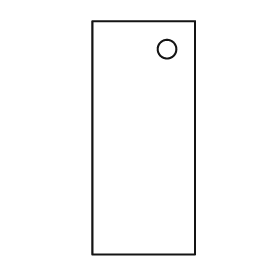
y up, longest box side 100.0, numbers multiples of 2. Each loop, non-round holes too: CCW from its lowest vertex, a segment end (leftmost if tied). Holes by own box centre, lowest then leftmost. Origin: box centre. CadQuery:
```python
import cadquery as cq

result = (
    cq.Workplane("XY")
    .moveTo(-22.0, -50.0)
    .lineTo(22.0, -50.0)
    .lineTo(22.0, 50.0)
    .lineTo(-22.0, 50.0)
    .close()
    .moveTo(10.0, 38.0)
    .circle(4.0)
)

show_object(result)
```